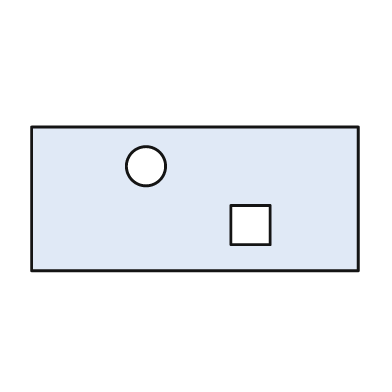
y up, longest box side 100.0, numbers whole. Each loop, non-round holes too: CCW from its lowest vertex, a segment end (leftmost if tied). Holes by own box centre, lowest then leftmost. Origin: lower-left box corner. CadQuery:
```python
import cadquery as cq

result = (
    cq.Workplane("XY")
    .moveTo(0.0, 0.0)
    .lineTo(100.0, 0.0)
    .lineTo(100.0, 44.0)
    .lineTo(0.0, 44.0)
    .close()
    .moveTo(61.0, 8.0)
    .lineTo(73.0, 8.0)
    .lineTo(73.0, 20.0)
    .lineTo(61.0, 20.0)
    .close()
    .moveTo(35.0, 32.0)
    .circle(6.0)
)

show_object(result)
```